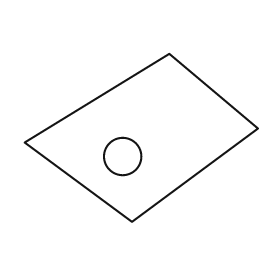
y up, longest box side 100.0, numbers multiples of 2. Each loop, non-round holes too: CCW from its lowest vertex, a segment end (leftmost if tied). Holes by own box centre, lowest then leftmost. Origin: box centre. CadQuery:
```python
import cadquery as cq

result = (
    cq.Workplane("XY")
    .moveTo(-4.0, -36.0)
    .lineTo(50.0, 4.0)
    .lineTo(12.0, 36.0)
    .lineTo(-50.0, -2.0)
    .close()
    .moveTo(-8.0, -8.0)
    .circle(8.0)
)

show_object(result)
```